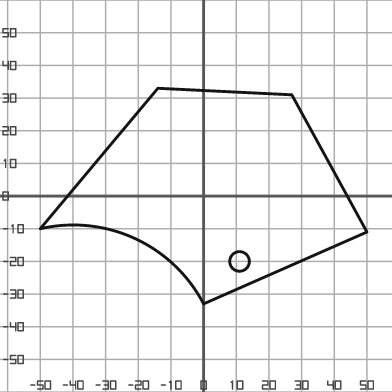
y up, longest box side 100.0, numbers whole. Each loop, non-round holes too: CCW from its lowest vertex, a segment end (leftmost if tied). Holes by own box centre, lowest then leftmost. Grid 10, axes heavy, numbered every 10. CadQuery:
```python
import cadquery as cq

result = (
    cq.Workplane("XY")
    .moveTo(0.0, -33.0)
    .lineTo(50.0, -11.0)
    .lineTo(27.0, 31.0)
    .lineTo(-14.0, 33.0)
    .lineTo(-50.0, -10.0)
    .threePointArc((-21.0, -13.0), (0.0, -33.0))
    .close()
    .moveTo(11.0, -20.0)
    .circle(3.0)
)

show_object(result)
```